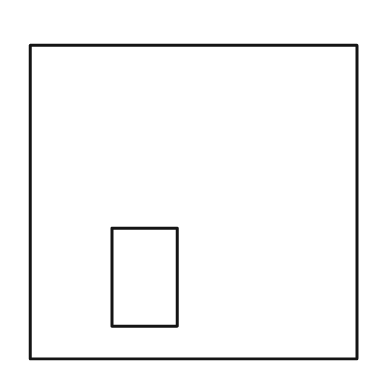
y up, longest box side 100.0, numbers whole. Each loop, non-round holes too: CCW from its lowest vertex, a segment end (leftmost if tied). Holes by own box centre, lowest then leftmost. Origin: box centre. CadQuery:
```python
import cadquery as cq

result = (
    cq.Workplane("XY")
    .moveTo(-50.0, -48.0)
    .lineTo(50.0, -48.0)
    .lineTo(50.0, 48.0)
    .lineTo(-50.0, 48.0)
    .close()
    .moveTo(-25.0, -38.0)
    .lineTo(-5.0, -38.0)
    .lineTo(-5.0, -8.0)
    .lineTo(-25.0, -8.0)
    .close()
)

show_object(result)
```